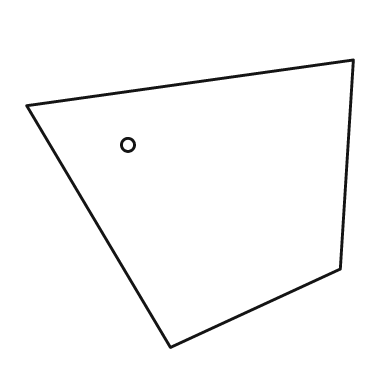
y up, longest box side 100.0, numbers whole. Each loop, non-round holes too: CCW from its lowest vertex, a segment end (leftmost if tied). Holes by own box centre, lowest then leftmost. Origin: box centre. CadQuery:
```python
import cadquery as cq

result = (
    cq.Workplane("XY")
    .moveTo(-6.0, -44.0)
    .lineTo(46.0, -20.0)
    .lineTo(50.0, 44.0)
    .lineTo(-50.0, 30.0)
    .close()
    .moveTo(-19.0, 18.0)
    .circle(2.0)
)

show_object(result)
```